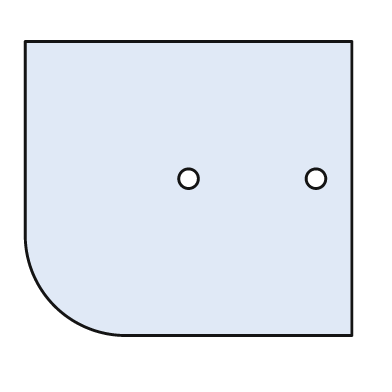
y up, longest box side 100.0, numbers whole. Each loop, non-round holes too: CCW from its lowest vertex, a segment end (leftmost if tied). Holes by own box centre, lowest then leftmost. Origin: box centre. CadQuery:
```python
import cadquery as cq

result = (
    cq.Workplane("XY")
    .moveTo(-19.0, -45.0)
    .lineTo(50.0, -45.0)
    .lineTo(50.0, 45.0)
    .lineTo(-50.0, 45.0)
    .lineTo(-50.0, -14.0)
    .threePointArc((-41.0, -36.0), (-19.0, -45.0))
    .close()
    .moveTo(0.0, 3.0)
    .circle(3.0)
    .moveTo(39.0, 3.0)
    .circle(3.0)
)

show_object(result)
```